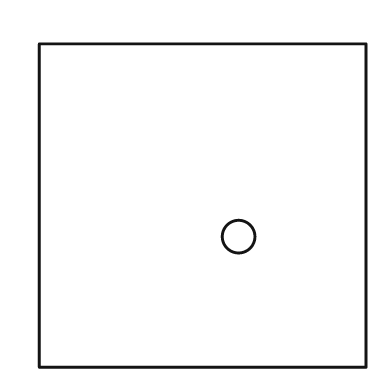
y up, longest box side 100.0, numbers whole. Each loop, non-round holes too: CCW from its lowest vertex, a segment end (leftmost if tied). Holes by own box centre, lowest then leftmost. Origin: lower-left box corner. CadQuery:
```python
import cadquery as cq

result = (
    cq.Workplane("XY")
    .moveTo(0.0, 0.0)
    .lineTo(100.0, 0.0)
    .lineTo(100.0, 99.0)
    .lineTo(0.0, 99.0)
    .close()
    .moveTo(61.0, 40.0)
    .circle(5.0)
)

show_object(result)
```